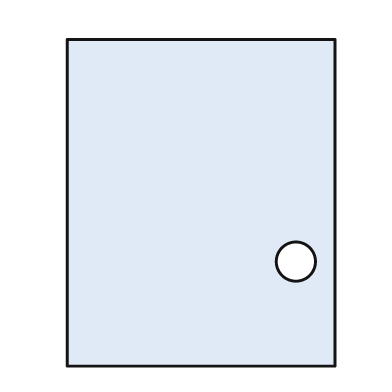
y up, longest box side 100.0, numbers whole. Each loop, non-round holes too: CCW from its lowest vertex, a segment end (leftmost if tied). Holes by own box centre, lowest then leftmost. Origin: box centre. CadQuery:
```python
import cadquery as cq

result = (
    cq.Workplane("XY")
    .moveTo(-41.0, -50.0)
    .lineTo(41.0, -50.0)
    .lineTo(41.0, 50.0)
    .lineTo(-41.0, 50.0)
    .close()
    .moveTo(29.0, -18.0)
    .circle(6.0)
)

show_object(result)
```